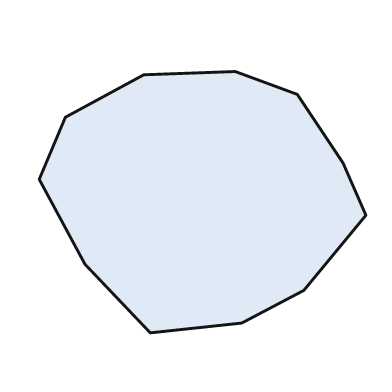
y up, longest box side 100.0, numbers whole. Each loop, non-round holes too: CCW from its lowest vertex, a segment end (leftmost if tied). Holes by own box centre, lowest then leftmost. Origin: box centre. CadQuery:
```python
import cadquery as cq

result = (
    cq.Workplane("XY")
    .moveTo(-16.0, -40.0)
    .lineTo(12.0, -37.0)
    .lineTo(31.0, -27.0)
    .lineTo(50.0, -4.0)
    .lineTo(43.0, 12.0)
    .lineTo(29.0, 33.0)
    .lineTo(10.0, 40.0)
    .lineTo(-18.0, 39.0)
    .lineTo(-42.0, 26.0)
    .lineTo(-50.0, 7.0)
    .lineTo(-36.0, -19.0)
    .close()
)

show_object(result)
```